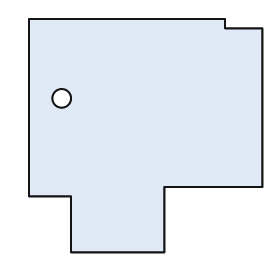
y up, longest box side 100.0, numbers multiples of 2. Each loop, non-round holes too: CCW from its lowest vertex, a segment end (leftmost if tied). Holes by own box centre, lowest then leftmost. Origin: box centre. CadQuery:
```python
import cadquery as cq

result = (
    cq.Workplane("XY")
    .moveTo(-32.0, -50.0)
    .lineTo(8.0, -50.0)
    .lineTo(8.0, -22.0)
    .lineTo(50.0, -22.0)
    .lineTo(50.0, 46.0)
    .lineTo(34.0, 46.0)
    .lineTo(34.0, 50.0)
    .lineTo(-50.0, 50.0)
    .lineTo(-50.0, -26.0)
    .lineTo(-32.0, -26.0)
    .close()
    .moveTo(-36.0, 16.0)
    .circle(4.0)
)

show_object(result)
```